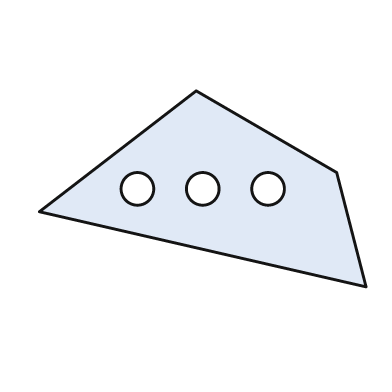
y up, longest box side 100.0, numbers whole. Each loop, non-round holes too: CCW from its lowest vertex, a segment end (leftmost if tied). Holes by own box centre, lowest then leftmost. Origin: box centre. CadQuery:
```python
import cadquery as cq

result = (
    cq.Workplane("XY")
    .moveTo(50.0, -30.0)
    .lineTo(41.0, 5.0)
    .lineTo(-2.0, 30.0)
    .lineTo(-50.0, -7.0)
    .close()
    .moveTo(-20.0, 0.0)
    .circle(5.0)
    .moveTo(0.0, 0.0)
    .circle(5.0)
    .moveTo(20.0, 0.0)
    .circle(5.0)
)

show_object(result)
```